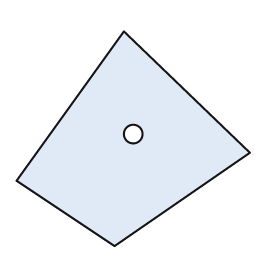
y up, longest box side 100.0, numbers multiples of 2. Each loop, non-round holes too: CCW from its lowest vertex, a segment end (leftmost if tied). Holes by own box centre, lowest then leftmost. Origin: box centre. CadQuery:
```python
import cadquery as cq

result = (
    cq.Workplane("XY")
    .moveTo(-8.0, -46.0)
    .lineTo(50.0, -6.0)
    .lineTo(-4.0, 46.0)
    .lineTo(-50.0, -18.0)
    .close()
    .moveTo(0.0, 2.0)
    .circle(4.0)
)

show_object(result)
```